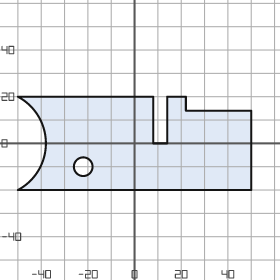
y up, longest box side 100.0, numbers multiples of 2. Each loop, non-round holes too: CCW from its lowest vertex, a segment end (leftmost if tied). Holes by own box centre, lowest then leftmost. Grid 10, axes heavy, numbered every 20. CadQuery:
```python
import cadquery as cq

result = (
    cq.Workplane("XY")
    .moveTo(-50.0, -20.0)
    .lineTo(50.0, -20.0)
    .lineTo(50.0, 14.0)
    .lineTo(22.0, 14.0)
    .lineTo(22.0, 20.0)
    .lineTo(14.0, 20.0)
    .lineTo(14.0, 0.0)
    .lineTo(8.0, 0.0)
    .lineTo(8.0, 20.0)
    .lineTo(-50.0, 20.0)
    .threePointArc((-38.0, 0.0), (-50.0, -20.0))
    .close()
    .moveTo(-22.0, -10.0)
    .circle(4.0)
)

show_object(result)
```